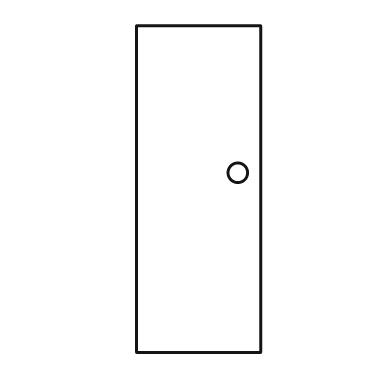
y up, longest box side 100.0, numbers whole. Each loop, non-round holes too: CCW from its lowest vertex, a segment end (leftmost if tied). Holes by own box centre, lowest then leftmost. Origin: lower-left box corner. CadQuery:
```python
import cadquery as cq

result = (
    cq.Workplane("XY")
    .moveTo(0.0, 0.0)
    .lineTo(38.0, 0.0)
    .lineTo(38.0, 100.0)
    .lineTo(0.0, 100.0)
    .close()
    .moveTo(31.0, 55.0)
    .circle(3.0)
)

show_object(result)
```